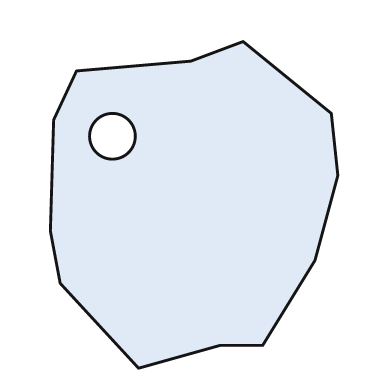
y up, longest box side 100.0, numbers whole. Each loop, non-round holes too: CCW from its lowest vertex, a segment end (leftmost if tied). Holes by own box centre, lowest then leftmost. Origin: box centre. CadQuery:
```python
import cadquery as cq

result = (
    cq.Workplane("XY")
    .moveTo(-17.0, -50.0)
    .lineTo(8.0, -43.0)
    .lineTo(21.0, -43.0)
    .lineTo(37.0, -17.0)
    .lineTo(44.0, 9.0)
    .lineTo(42.0, 28.0)
    .lineTo(15.0, 50.0)
    .lineTo(-1.0, 44.0)
    .lineTo(-36.0, 41.0)
    .lineTo(-43.0, 26.0)
    .lineTo(-44.0, -8.0)
    .lineTo(-41.0, -24.0)
    .close()
    .moveTo(-25.0, 21.0)
    .circle(7.0)
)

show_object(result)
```